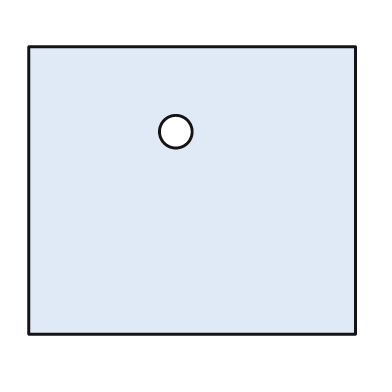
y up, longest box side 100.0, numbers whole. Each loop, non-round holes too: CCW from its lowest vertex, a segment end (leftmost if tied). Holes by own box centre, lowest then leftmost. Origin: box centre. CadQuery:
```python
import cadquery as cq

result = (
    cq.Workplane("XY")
    .moveTo(-50.0, -44.0)
    .lineTo(50.0, -44.0)
    .lineTo(50.0, 44.0)
    .lineTo(-50.0, 44.0)
    .close()
    .moveTo(-5.0, 18.0)
    .circle(5.0)
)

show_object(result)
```